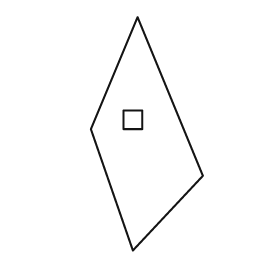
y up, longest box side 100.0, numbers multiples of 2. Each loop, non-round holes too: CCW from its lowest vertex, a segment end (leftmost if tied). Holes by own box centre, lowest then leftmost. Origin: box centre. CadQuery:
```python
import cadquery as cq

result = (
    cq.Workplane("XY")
    .moveTo(-6.0, -50.0)
    .lineTo(24.0, -18.0)
    .lineTo(-4.0, 50.0)
    .lineTo(-24.0, 2.0)
    .close()
    .moveTo(-10.0, 2.0)
    .lineTo(-2.0, 2.0)
    .lineTo(-2.0, 10.0)
    .lineTo(-10.0, 10.0)
    .close()
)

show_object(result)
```